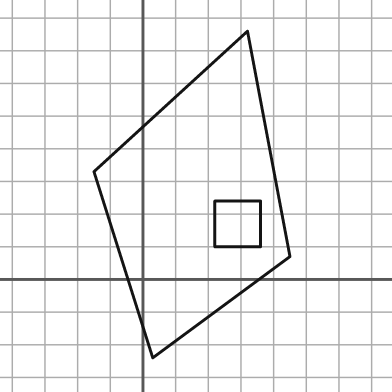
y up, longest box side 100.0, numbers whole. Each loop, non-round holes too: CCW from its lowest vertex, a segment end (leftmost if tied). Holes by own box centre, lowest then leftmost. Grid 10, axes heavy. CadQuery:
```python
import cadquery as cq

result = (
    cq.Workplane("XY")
    .moveTo(3.0, -24.0)
    .lineTo(45.0, 7.0)
    .lineTo(32.0, 76.0)
    .lineTo(-15.0, 33.0)
    .close()
    .moveTo(22.0, 10.0)
    .lineTo(36.0, 10.0)
    .lineTo(36.0, 24.0)
    .lineTo(22.0, 24.0)
    .close()
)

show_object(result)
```